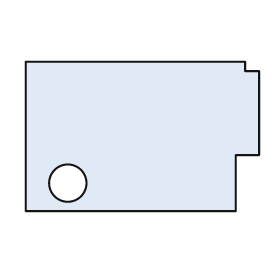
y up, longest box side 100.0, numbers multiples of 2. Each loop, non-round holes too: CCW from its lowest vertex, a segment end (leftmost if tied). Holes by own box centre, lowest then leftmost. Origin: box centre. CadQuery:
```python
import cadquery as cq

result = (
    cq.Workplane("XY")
    .moveTo(-50.0, -32.0)
    .lineTo(40.0, -32.0)
    .lineTo(40.0, -8.0)
    .lineTo(50.0, -8.0)
    .lineTo(50.0, 28.0)
    .lineTo(44.0, 28.0)
    .lineTo(44.0, 32.0)
    .lineTo(-50.0, 32.0)
    .close()
    .moveTo(-32.0, -20.0)
    .circle(8.0)
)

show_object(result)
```